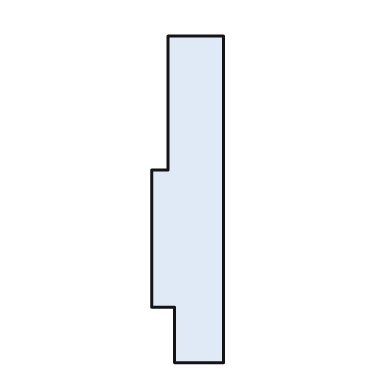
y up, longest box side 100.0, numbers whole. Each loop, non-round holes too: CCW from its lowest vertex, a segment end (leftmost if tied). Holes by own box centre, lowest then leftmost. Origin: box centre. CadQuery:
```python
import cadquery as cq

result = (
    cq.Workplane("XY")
    .moveTo(-4.0, -50.0)
    .lineTo(11.0, -50.0)
    .lineTo(11.0, 50.0)
    .lineTo(-6.0, 50.0)
    .lineTo(-6.0, 9.0)
    .lineTo(-11.0, 9.0)
    .lineTo(-11.0, -33.0)
    .lineTo(-4.0, -33.0)
    .close()
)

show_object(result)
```